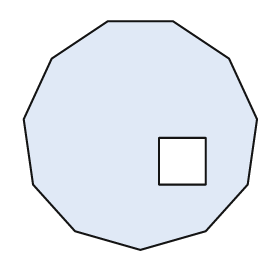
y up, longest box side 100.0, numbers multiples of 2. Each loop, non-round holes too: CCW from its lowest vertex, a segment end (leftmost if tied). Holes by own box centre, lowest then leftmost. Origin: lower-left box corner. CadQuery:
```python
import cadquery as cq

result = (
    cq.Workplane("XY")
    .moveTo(50.0, 0.0)
    .lineTo(78.0, 8.0)
    .lineTo(96.0, 28.0)
    .lineTo(100.0, 56.0)
    .lineTo(88.0, 82.0)
    .lineTo(64.0, 98.0)
    .lineTo(36.0, 98.0)
    .lineTo(12.0, 82.0)
    .lineTo(0.0, 56.0)
    .lineTo(4.0, 28.0)
    .lineTo(22.0, 8.0)
    .close()
    .moveTo(58.0, 28.0)
    .lineTo(78.0, 28.0)
    .lineTo(78.0, 48.0)
    .lineTo(58.0, 48.0)
    .close()
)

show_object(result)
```